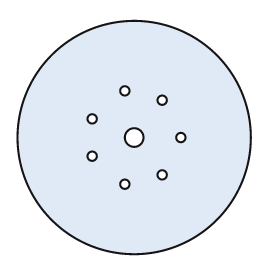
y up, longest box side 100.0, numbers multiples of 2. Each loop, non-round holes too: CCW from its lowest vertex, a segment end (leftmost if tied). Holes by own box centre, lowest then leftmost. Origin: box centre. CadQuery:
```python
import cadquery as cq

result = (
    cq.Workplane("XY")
    .moveTo(0.0, 0.0)
    .circle(50.0)
    .moveTo(-4.0, -20.0)
    .circle(2.0)
    .moveTo(12.0, -16.0)
    .circle(2.0)
    .moveTo(-18.0, -8.0)
    .circle(2.0)
    .moveTo(0.0, 0.0)
    .circle(4.0)
    .moveTo(20.0, 0.0)
    .circle(2.0)
    .moveTo(-18.0, 8.0)
    .circle(2.0)
    .moveTo(12.0, 16.0)
    .circle(2.0)
    .moveTo(-4.0, 20.0)
    .circle(2.0)
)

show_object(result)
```